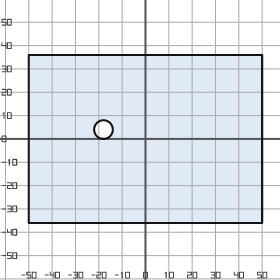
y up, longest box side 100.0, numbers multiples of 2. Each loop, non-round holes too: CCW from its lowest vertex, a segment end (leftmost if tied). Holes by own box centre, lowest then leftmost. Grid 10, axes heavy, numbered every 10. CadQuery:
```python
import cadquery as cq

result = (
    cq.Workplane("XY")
    .moveTo(-50.0, -36.0)
    .lineTo(50.0, -36.0)
    .lineTo(50.0, 36.0)
    .lineTo(-50.0, 36.0)
    .close()
    .moveTo(-18.0, 4.0)
    .circle(4.0)
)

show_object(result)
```